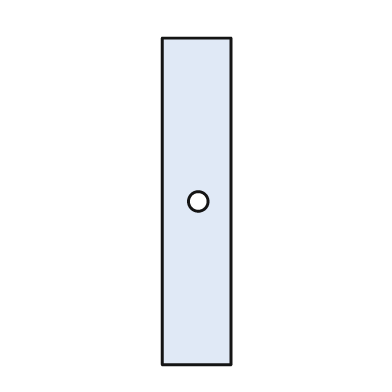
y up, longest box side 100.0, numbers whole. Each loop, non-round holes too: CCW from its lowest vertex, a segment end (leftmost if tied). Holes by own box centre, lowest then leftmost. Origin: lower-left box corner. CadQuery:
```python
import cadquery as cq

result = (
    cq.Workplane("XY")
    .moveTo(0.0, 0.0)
    .lineTo(21.0, 0.0)
    .lineTo(21.0, 100.0)
    .lineTo(0.0, 100.0)
    .close()
    .moveTo(11.0, 50.0)
    .circle(3.0)
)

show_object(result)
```